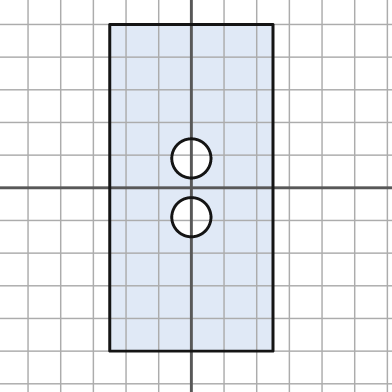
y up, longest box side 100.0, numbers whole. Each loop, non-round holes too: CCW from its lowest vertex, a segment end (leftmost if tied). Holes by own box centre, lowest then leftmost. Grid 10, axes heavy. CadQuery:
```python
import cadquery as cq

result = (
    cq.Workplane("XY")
    .moveTo(-25.0, -50.0)
    .lineTo(25.0, -50.0)
    .lineTo(25.0, 50.0)
    .lineTo(-25.0, 50.0)
    .close()
    .moveTo(0.0, -9.0)
    .circle(6.0)
    .moveTo(0.0, 9.0)
    .circle(6.0)
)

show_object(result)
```